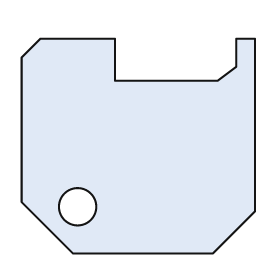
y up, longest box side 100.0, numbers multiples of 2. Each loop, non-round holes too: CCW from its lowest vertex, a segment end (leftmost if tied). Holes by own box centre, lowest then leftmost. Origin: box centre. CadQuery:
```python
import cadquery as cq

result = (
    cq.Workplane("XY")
    .moveTo(-28.0, -46.0)
    .lineTo(32.0, -46.0)
    .lineTo(50.0, -28.0)
    .lineTo(50.0, 46.0)
    .lineTo(42.0, 46.0)
    .lineTo(42.0, 34.0)
    .lineTo(34.0, 28.0)
    .lineTo(-10.0, 28.0)
    .lineTo(-10.0, 46.0)
    .lineTo(-42.0, 46.0)
    .lineTo(-50.0, 38.0)
    .lineTo(-50.0, -24.0)
    .close()
    .moveTo(-26.0, -26.0)
    .circle(8.0)
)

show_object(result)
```